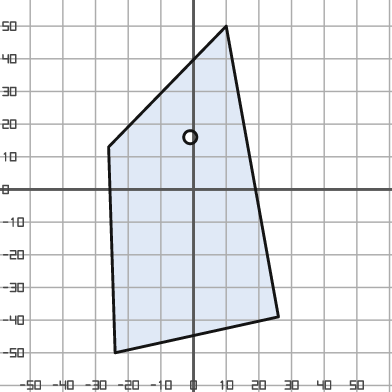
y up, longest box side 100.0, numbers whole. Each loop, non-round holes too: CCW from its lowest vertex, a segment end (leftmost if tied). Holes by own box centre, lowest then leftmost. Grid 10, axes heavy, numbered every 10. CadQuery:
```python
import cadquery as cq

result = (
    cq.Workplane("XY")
    .moveTo(-24.0, -50.0)
    .lineTo(26.0, -39.0)
    .lineTo(10.0, 50.0)
    .lineTo(-26.0, 13.0)
    .close()
    .moveTo(-1.0, 16.0)
    .circle(2.0)
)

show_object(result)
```